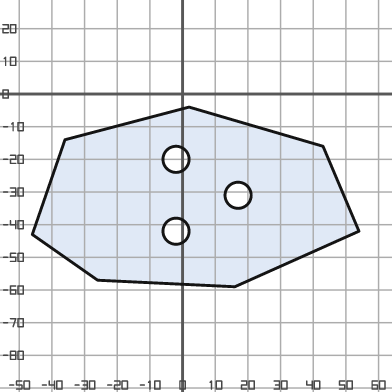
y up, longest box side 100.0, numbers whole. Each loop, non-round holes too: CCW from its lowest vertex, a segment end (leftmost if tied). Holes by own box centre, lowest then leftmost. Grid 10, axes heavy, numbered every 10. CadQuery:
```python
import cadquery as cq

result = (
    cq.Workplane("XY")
    .moveTo(16.0, -59.0)
    .lineTo(54.0, -42.0)
    .lineTo(43.0, -16.0)
    .lineTo(2.0, -4.0)
    .lineTo(-36.0, -14.0)
    .lineTo(-46.0, -43.0)
    .lineTo(-26.0, -57.0)
    .close()
    .moveTo(-2.0, -42.0)
    .circle(4.0)
    .moveTo(17.0, -31.0)
    .circle(4.0)
    .moveTo(-2.0, -20.0)
    .circle(4.0)
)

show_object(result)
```